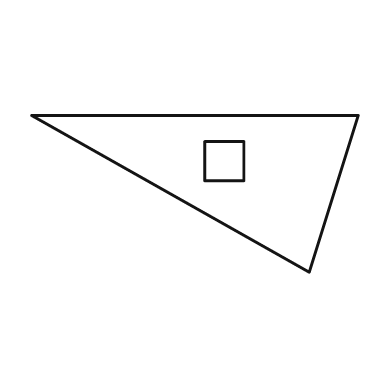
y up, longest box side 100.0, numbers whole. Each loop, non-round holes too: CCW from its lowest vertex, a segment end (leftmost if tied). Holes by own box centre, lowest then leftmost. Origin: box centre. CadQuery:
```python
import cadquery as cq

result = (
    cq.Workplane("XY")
    .moveTo(35.0, -24.0)
    .lineTo(50.0, 24.0)
    .lineTo(-50.0, 24.0)
    .close()
    .moveTo(3.0, 4.0)
    .lineTo(15.0, 4.0)
    .lineTo(15.0, 16.0)
    .lineTo(3.0, 16.0)
    .close()
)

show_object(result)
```